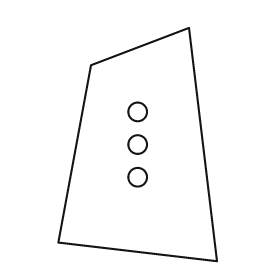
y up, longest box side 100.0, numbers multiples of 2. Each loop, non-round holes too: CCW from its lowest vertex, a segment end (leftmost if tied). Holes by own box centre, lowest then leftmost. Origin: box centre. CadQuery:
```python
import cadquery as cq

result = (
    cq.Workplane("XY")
    .moveTo(34.0, -50.0)
    .lineTo(22.0, 50.0)
    .lineTo(-20.0, 34.0)
    .lineTo(-34.0, -42.0)
    .close()
    .moveTo(0.0, -14.0)
    .circle(4.0)
    .moveTo(0.0, 0.0)
    .circle(4.0)
    .moveTo(0.0, 14.0)
    .circle(4.0)
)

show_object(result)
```